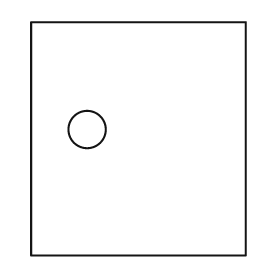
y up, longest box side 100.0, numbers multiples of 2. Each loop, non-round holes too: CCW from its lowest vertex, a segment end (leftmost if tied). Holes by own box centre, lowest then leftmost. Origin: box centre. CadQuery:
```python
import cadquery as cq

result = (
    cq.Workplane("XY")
    .moveTo(-46.0, -50.0)
    .lineTo(46.0, -50.0)
    .lineTo(46.0, 50.0)
    .lineTo(-46.0, 50.0)
    .close()
    .moveTo(-22.0, 4.0)
    .circle(8.0)
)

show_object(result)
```